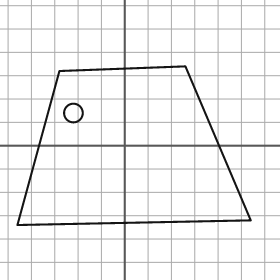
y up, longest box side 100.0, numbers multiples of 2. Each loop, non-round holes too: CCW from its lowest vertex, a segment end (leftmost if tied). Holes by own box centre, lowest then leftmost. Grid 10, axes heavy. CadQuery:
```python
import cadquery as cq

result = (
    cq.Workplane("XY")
    .moveTo(-46.0, -34.0)
    .lineTo(54.0, -32.0)
    .lineTo(26.0, 34.0)
    .lineTo(-28.0, 32.0)
    .close()
    .moveTo(-22.0, 14.0)
    .circle(4.0)
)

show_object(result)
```